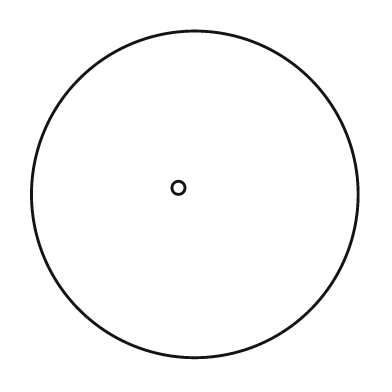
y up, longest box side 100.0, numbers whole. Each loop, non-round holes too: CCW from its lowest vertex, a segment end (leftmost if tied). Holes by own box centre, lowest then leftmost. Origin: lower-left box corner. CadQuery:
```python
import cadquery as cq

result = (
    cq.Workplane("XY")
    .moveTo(50.0, 50.0)
    .circle(50.0)
    .moveTo(45.0, 52.0)
    .circle(2.0)
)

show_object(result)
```